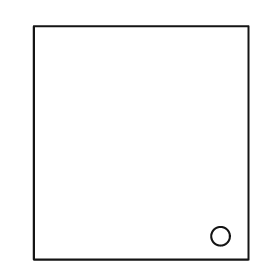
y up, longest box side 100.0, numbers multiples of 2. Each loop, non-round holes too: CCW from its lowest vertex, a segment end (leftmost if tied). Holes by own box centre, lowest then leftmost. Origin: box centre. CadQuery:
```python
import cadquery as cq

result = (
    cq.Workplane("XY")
    .moveTo(-46.0, -50.0)
    .lineTo(46.0, -50.0)
    .lineTo(46.0, 50.0)
    .lineTo(-46.0, 50.0)
    .close()
    .moveTo(34.0, -40.0)
    .circle(4.0)
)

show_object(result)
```